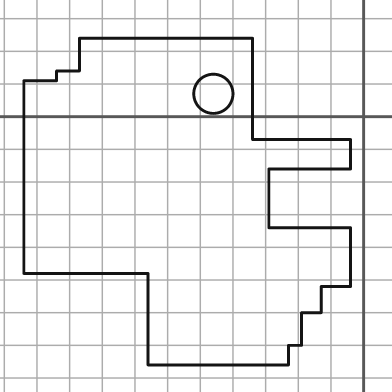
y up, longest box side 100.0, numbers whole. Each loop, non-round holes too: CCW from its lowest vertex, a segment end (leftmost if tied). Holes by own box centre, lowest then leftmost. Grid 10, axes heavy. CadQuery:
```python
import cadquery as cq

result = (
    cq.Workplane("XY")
    .moveTo(-66.0, -76.0)
    .lineTo(-23.0, -76.0)
    .lineTo(-23.0, -70.0)
    .lineTo(-19.0, -70.0)
    .lineTo(-19.0, -60.0)
    .lineTo(-13.0, -60.0)
    .lineTo(-13.0, -52.0)
    .lineTo(-4.0, -52.0)
    .lineTo(-4.0, -34.0)
    .lineTo(-29.0, -34.0)
    .lineTo(-29.0, -16.0)
    .lineTo(-4.0, -16.0)
    .lineTo(-4.0, -7.0)
    .lineTo(-34.0, -7.0)
    .lineTo(-34.0, 24.0)
    .lineTo(-87.0, 24.0)
    .lineTo(-87.0, 14.0)
    .lineTo(-94.0, 14.0)
    .lineTo(-94.0, 11.0)
    .lineTo(-104.0, 11.0)
    .lineTo(-104.0, -48.0)
    .lineTo(-66.0, -48.0)
    .close()
    .moveTo(-46.0, 7.0)
    .circle(6.0)
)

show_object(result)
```